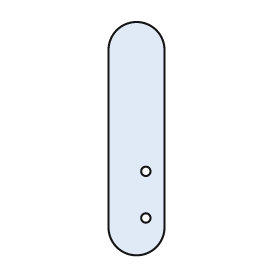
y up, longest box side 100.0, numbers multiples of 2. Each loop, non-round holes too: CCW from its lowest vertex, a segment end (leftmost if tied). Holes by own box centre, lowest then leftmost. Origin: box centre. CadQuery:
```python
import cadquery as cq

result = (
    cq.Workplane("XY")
    .moveTo(-12.0, -38.0)
    .threePointArc((0.0, -50.0), (12.0, -38.0))
    .lineTo(12.0, 38.0)
    .threePointArc((0.0, 50.0), (-12.0, 38.0))
    .close()
    .moveTo(4.0, -34.0)
    .circle(2.0)
    .moveTo(4.0, -14.0)
    .circle(2.0)
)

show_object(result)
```